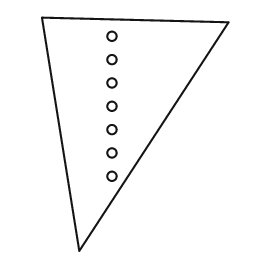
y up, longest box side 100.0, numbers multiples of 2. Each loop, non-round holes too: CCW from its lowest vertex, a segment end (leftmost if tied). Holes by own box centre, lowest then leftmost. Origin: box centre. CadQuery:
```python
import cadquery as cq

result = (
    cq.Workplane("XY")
    .moveTo(-24.0, -50.0)
    .lineTo(40.0, 48.0)
    .lineTo(-40.0, 50.0)
    .close()
    .moveTo(-10.0, -18.0)
    .circle(2.0)
    .moveTo(-10.0, -8.0)
    .circle(2.0)
    .moveTo(-10.0, 2.0)
    .circle(2.0)
    .moveTo(-10.0, 12.0)
    .circle(2.0)
    .moveTo(-10.0, 22.0)
    .circle(2.0)
    .moveTo(-10.0, 32.0)
    .circle(2.0)
    .moveTo(-10.0, 42.0)
    .circle(2.0)
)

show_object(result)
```